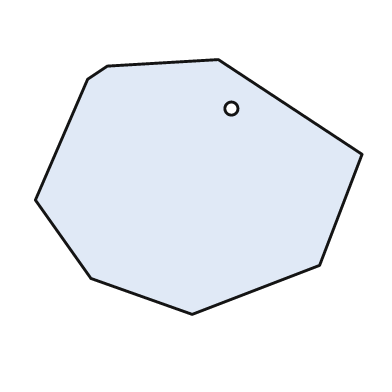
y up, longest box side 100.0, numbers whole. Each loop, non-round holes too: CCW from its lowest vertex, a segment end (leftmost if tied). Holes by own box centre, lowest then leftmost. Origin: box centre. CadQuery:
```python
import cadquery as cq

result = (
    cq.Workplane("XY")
    .moveTo(-2.0, -39.0)
    .lineTo(37.0, -24.0)
    .lineTo(50.0, 10.0)
    .lineTo(6.0, 39.0)
    .lineTo(-28.0, 37.0)
    .lineTo(-34.0, 33.0)
    .lineTo(-50.0, -4.0)
    .lineTo(-33.0, -28.0)
    .close()
    .moveTo(10.0, 24.0)
    .circle(2.0)
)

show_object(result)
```